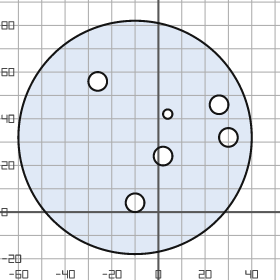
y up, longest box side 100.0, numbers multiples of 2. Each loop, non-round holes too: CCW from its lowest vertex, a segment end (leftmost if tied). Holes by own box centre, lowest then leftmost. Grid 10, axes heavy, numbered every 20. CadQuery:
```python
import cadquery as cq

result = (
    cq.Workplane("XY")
    .moveTo(-10.0, 32.0)
    .circle(50.0)
    .moveTo(-10.0, 4.0)
    .circle(4.0)
    .moveTo(2.0, 24.0)
    .circle(4.0)
    .moveTo(30.0, 32.0)
    .circle(4.0)
    .moveTo(4.0, 42.0)
    .circle(2.0)
    .moveTo(26.0, 46.0)
    .circle(4.0)
    .moveTo(-26.0, 56.0)
    .circle(4.0)
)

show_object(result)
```